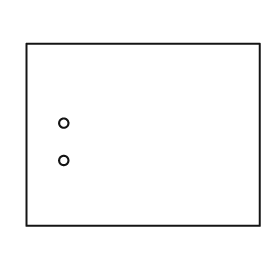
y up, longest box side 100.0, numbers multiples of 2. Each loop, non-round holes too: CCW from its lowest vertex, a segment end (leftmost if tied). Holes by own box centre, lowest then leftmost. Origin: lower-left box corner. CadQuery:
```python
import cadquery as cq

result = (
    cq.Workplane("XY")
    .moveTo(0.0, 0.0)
    .lineTo(100.0, 0.0)
    .lineTo(100.0, 78.0)
    .lineTo(0.0, 78.0)
    .close()
    .moveTo(16.0, 28.0)
    .circle(2.0)
    .moveTo(16.0, 44.0)
    .circle(2.0)
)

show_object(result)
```